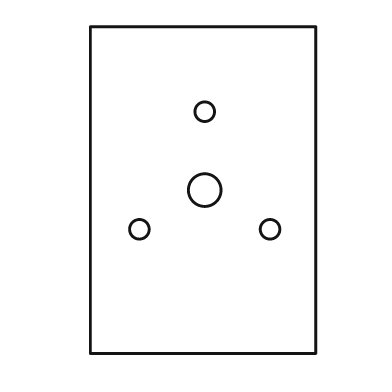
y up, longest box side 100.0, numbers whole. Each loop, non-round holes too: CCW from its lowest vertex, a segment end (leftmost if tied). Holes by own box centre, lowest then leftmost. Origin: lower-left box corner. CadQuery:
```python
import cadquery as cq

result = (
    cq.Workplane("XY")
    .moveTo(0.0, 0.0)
    .lineTo(69.0, 0.0)
    .lineTo(69.0, 100.0)
    .lineTo(0.0, 100.0)
    .close()
    .moveTo(15.0, 38.0)
    .circle(3.0)
    .moveTo(55.0, 38.0)
    .circle(3.0)
    .moveTo(35.0, 50.0)
    .circle(5.0)
    .moveTo(35.0, 74.0)
    .circle(3.0)
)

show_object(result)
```